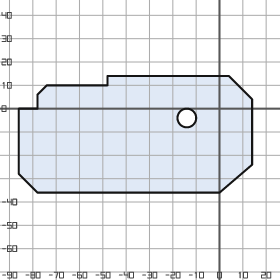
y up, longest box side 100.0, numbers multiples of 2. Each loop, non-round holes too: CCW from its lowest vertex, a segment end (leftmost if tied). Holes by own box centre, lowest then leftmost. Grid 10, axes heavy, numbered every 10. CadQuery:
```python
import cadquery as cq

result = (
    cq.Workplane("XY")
    .moveTo(-78.0, -36.0)
    .lineTo(0.0, -36.0)
    .lineTo(14.0, -24.0)
    .lineTo(14.0, 4.0)
    .lineTo(4.0, 14.0)
    .lineTo(-48.0, 14.0)
    .lineTo(-48.0, 10.0)
    .lineTo(-74.0, 10.0)
    .lineTo(-78.0, 6.0)
    .lineTo(-78.0, 0.0)
    .lineTo(-86.0, 0.0)
    .lineTo(-86.0, -28.0)
    .close()
    .moveTo(-14.0, -4.0)
    .circle(4.0)
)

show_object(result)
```